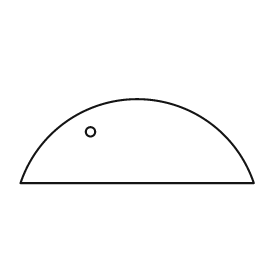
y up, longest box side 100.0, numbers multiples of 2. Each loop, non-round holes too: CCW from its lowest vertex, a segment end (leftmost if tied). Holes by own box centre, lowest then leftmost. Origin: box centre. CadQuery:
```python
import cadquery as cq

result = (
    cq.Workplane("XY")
    .moveTo(-50.0, -18.0)
    .lineTo(50.0, -18.0)
    .threePointArc((0.0, 18.0), (-50.0, -18.0))
    .close()
    .moveTo(-20.0, 4.0)
    .circle(2.0)
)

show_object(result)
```